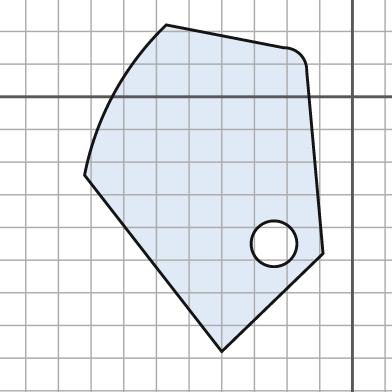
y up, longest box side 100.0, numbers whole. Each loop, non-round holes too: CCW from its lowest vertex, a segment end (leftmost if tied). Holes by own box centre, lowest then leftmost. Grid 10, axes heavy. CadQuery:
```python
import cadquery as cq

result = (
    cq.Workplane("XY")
    .moveTo(-40.0, -78.0)
    .lineTo(-9.0, -48.0)
    .lineTo(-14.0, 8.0)
    .threePointArc((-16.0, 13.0), (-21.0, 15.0))
    .lineTo(-57.0, 22.0)
    .threePointArc((-73.0, 1.0), (-82.0, -24.0))
    .close()
    .moveTo(-24.0, -45.0)
    .circle(7.0)
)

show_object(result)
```